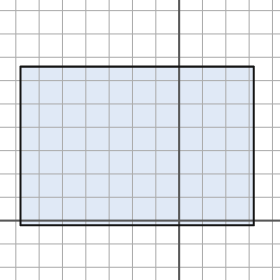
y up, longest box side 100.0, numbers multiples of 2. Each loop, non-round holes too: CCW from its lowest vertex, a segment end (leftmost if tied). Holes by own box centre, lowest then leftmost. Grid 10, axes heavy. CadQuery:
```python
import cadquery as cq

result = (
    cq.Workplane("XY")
    .moveTo(-68.0, -2.0)
    .lineTo(32.0, -2.0)
    .lineTo(32.0, 66.0)
    .lineTo(-68.0, 66.0)
    .close()
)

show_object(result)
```